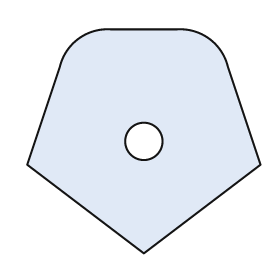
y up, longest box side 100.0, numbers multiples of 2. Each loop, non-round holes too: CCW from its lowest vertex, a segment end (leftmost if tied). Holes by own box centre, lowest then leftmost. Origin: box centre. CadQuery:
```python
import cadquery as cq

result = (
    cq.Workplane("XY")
    .moveTo(0.0, -48.0)
    .lineTo(50.0, -10.0)
    .lineTo(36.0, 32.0)
    .threePointArc((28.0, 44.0), (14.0, 48.0))
    .lineTo(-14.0, 48.0)
    .threePointArc((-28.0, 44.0), (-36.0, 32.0))
    .lineTo(-50.0, -10.0)
    .close()
    .moveTo(0.0, 0.0)
    .circle(8.0)
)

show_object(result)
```